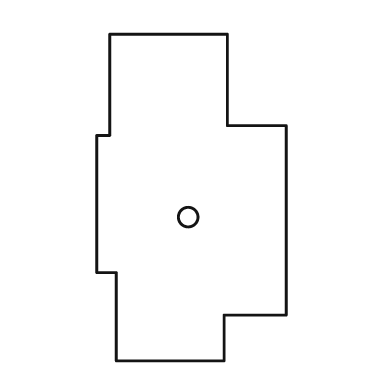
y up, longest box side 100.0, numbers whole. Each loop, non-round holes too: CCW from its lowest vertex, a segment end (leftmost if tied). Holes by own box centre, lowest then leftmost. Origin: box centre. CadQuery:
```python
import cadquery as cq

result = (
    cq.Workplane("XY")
    .moveTo(-23.0, -50.0)
    .lineTo(10.0, -50.0)
    .lineTo(10.0, -36.0)
    .lineTo(29.0, -36.0)
    .lineTo(29.0, 22.0)
    .lineTo(11.0, 22.0)
    .lineTo(11.0, 50.0)
    .lineTo(-25.0, 50.0)
    .lineTo(-25.0, 19.0)
    .lineTo(-29.0, 19.0)
    .lineTo(-29.0, -23.0)
    .lineTo(-23.0, -23.0)
    .close()
    .moveTo(-1.0, -6.0)
    .circle(3.0)
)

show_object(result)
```